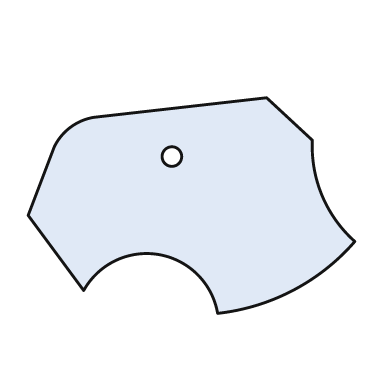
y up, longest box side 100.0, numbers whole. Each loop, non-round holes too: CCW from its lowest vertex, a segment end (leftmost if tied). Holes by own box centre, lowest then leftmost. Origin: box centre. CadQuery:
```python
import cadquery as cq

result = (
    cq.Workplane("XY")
    .moveTo(8.0, -33.0)
    .threePointArc((31.0, -26.0), (50.0, -11.0))
    .threePointArc((40.0, 3.0), (37.0, 20.0))
    .lineTo(23.0, 33.0)
    .lineTo(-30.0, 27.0)
    .threePointArc((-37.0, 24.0), (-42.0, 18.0))
    .lineTo(-50.0, -3.0)
    .lineTo(-33.0, -26.0)
    .threePointArc((-10.0, -15.0), (8.0, -33.0))
    .close()
    .moveTo(-6.0, 15.0)
    .circle(3.0)
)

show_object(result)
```